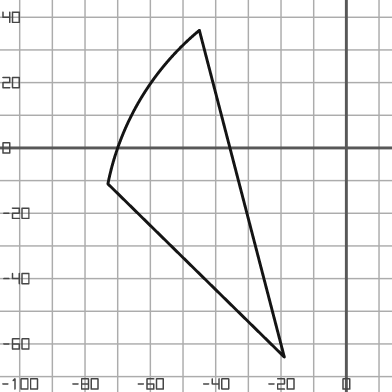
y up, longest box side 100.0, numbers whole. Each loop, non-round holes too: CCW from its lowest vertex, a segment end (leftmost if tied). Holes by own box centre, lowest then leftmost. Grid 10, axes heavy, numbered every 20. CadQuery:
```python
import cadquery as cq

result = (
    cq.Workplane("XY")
    .moveTo(-19.0, -64.0)
    .lineTo(-45.0, 36.0)
    .threePointArc((-63.0, 15.0), (-73.0, -11.0))
    .close()
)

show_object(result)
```